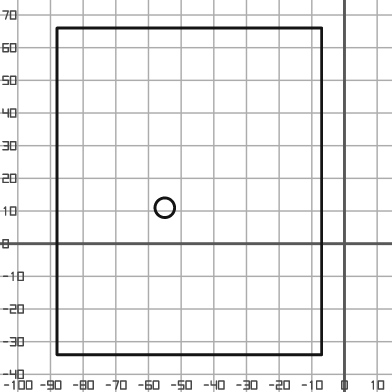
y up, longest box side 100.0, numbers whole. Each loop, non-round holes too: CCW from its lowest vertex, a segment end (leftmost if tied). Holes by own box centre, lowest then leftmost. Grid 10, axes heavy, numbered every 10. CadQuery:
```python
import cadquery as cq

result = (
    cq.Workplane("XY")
    .moveTo(-88.0, -34.0)
    .lineTo(-7.0, -34.0)
    .lineTo(-7.0, 66.0)
    .lineTo(-88.0, 66.0)
    .close()
    .moveTo(-55.0, 11.0)
    .circle(3.0)
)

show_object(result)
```